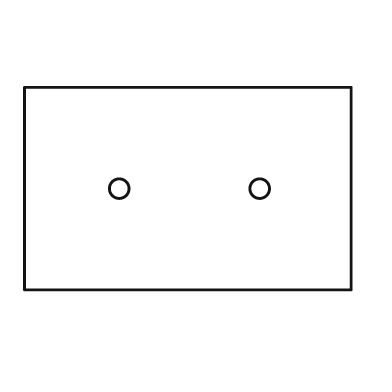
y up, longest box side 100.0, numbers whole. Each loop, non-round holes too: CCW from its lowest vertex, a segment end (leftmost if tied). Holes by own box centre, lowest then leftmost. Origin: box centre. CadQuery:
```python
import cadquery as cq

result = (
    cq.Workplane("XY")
    .moveTo(-50.0, -31.0)
    .lineTo(50.0, -31.0)
    .lineTo(50.0, 31.0)
    .lineTo(-50.0, 31.0)
    .close()
    .moveTo(-21.0, 0.0)
    .circle(3.0)
    .moveTo(22.0, 0.0)
    .circle(3.0)
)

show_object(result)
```